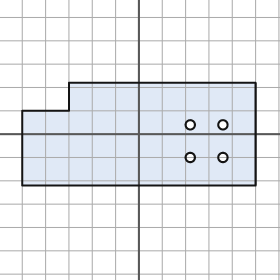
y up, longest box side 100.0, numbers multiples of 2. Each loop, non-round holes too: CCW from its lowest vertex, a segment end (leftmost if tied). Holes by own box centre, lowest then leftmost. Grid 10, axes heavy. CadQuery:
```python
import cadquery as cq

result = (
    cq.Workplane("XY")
    .moveTo(-50.0, -22.0)
    .lineTo(50.0, -22.0)
    .lineTo(50.0, 22.0)
    .lineTo(-30.0, 22.0)
    .lineTo(-30.0, 10.0)
    .lineTo(-50.0, 10.0)
    .close()
    .moveTo(22.0, -10.0)
    .circle(2.0)
    .moveTo(36.0, -10.0)
    .circle(2.0)
    .moveTo(22.0, 4.0)
    .circle(2.0)
    .moveTo(36.0, 4.0)
    .circle(2.0)
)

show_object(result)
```